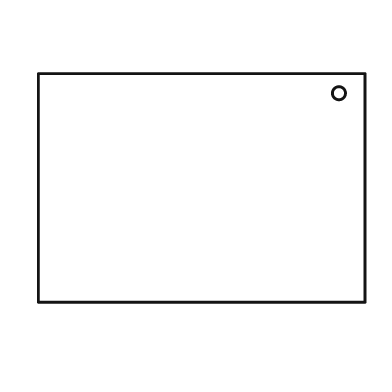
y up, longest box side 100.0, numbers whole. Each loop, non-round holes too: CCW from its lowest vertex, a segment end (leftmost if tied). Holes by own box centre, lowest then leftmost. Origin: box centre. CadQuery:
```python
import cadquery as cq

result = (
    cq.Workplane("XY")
    .moveTo(-50.0, -35.0)
    .lineTo(50.0, -35.0)
    .lineTo(50.0, 35.0)
    .lineTo(-50.0, 35.0)
    .close()
    .moveTo(42.0, 29.0)
    .circle(2.0)
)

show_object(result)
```